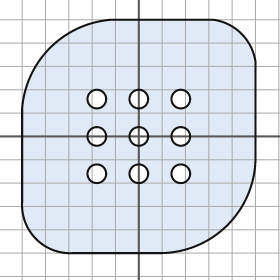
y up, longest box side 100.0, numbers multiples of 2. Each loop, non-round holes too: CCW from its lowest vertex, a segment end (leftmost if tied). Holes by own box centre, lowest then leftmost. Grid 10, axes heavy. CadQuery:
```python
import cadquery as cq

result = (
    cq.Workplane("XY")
    .moveTo(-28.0, -50.0)
    .lineTo(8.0, -50.0)
    .threePointArc((38.0, -38.0), (50.0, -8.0))
    .lineTo(50.0, 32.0)
    .threePointArc((44.0, 44.0), (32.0, 50.0))
    .lineTo(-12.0, 50.0)
    .threePointArc((-38.0, 38.0), (-50.0, 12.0))
    .lineTo(-50.0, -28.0)
    .threePointArc((-44.0, -44.0), (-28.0, -50.0))
    .close()
    .moveTo(-18.0, -16.0)
    .circle(4.0)
    .moveTo(0.0, -16.0)
    .circle(4.0)
    .moveTo(18.0, -16.0)
    .circle(4.0)
    .moveTo(-18.0, 0.0)
    .circle(4.0)
    .moveTo(0.0, 0.0)
    .circle(4.0)
    .moveTo(18.0, 0.0)
    .circle(4.0)
    .moveTo(-18.0, 16.0)
    .circle(4.0)
    .moveTo(0.0, 16.0)
    .circle(4.0)
    .moveTo(18.0, 16.0)
    .circle(4.0)
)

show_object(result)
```